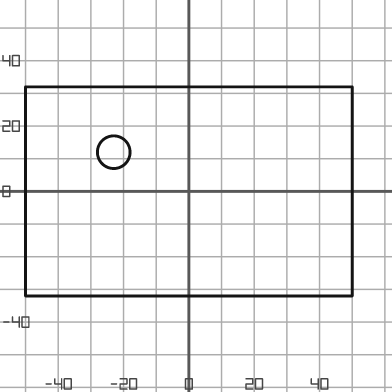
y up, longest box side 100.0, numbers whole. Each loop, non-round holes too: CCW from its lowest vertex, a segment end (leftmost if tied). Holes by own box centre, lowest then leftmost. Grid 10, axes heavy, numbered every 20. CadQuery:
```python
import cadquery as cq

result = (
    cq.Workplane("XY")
    .moveTo(-50.0, -32.0)
    .lineTo(50.0, -32.0)
    .lineTo(50.0, 32.0)
    .lineTo(-50.0, 32.0)
    .close()
    .moveTo(-23.0, 12.0)
    .circle(5.0)
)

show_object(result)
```